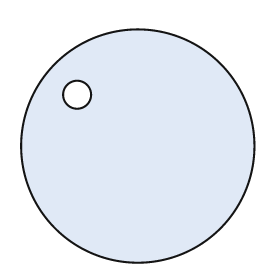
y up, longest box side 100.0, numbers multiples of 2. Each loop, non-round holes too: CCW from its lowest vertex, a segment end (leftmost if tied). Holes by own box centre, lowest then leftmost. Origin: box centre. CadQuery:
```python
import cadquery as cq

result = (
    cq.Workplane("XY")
    .moveTo(0.0, 0.0)
    .circle(50.0)
    .moveTo(-26.0, 22.0)
    .circle(6.0)
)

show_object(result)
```